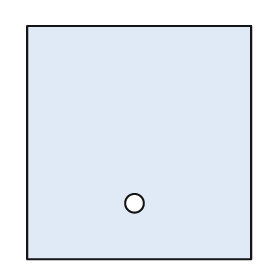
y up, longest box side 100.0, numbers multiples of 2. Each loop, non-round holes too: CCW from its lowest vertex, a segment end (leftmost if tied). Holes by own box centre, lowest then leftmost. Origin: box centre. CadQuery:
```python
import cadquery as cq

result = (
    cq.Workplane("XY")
    .moveTo(-48.0, -50.0)
    .lineTo(48.0, -50.0)
    .lineTo(48.0, 50.0)
    .lineTo(-48.0, 50.0)
    .close()
    .moveTo(-2.0, -26.0)
    .circle(4.0)
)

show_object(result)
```